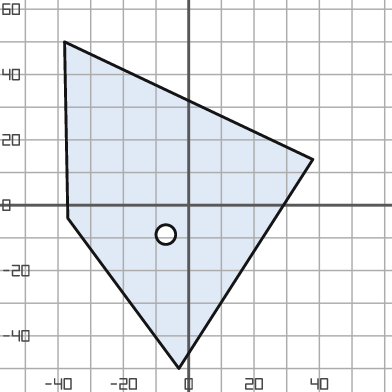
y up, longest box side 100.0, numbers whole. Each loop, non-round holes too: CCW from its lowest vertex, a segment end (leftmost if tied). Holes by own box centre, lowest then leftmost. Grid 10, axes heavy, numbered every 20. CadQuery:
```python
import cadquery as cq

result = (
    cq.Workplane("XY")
    .moveTo(-3.0, -50.0)
    .lineTo(38.0, 14.0)
    .lineTo(-38.0, 50.0)
    .lineTo(-37.0, -4.0)
    .close()
    .moveTo(-7.0, -9.0)
    .circle(3.0)
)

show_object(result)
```